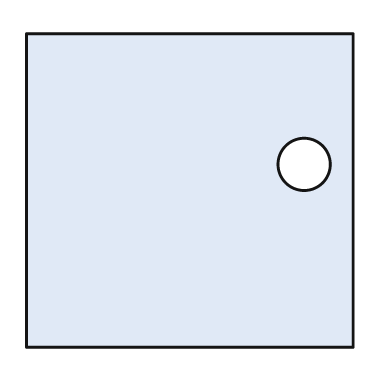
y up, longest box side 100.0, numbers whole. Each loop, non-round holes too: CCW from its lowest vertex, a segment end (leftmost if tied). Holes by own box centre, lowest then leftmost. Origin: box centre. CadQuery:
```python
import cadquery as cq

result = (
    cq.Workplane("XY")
    .moveTo(-50.0, -48.0)
    .lineTo(50.0, -48.0)
    .lineTo(50.0, 48.0)
    .lineTo(-50.0, 48.0)
    .close()
    .moveTo(35.0, 8.0)
    .circle(8.0)
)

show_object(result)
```